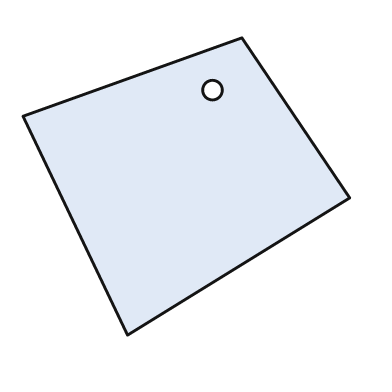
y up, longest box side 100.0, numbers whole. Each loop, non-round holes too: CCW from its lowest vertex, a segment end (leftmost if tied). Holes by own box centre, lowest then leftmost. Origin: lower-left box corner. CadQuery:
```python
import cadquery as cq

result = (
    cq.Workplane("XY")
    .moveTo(32.0, 0.0)
    .lineTo(100.0, 42.0)
    .lineTo(67.0, 91.0)
    .lineTo(0.0, 67.0)
    .close()
    .moveTo(58.0, 75.0)
    .circle(3.0)
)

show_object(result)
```